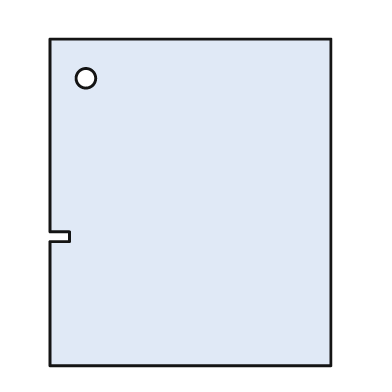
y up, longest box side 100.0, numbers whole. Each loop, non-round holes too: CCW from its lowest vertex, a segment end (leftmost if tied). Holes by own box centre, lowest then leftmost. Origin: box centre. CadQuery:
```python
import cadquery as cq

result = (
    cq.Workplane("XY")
    .moveTo(-43.0, -50.0)
    .lineTo(43.0, -50.0)
    .lineTo(43.0, 50.0)
    .lineTo(-43.0, 50.0)
    .lineTo(-43.0, -9.0)
    .lineTo(-37.0, -9.0)
    .lineTo(-37.0, -12.0)
    .lineTo(-43.0, -12.0)
    .close()
    .moveTo(-32.0, 38.0)
    .circle(3.0)
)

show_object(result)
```